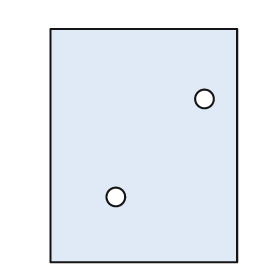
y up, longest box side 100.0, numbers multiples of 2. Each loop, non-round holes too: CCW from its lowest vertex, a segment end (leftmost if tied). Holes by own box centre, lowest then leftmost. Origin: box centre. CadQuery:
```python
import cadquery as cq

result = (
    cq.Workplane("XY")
    .moveTo(-40.0, -50.0)
    .lineTo(40.0, -50.0)
    .lineTo(40.0, 50.0)
    .lineTo(-40.0, 50.0)
    .close()
    .moveTo(-12.0, -22.0)
    .circle(4.0)
    .moveTo(26.0, 20.0)
    .circle(4.0)
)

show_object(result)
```